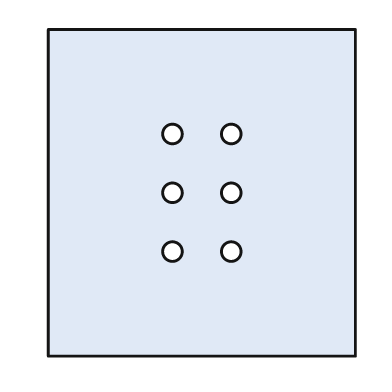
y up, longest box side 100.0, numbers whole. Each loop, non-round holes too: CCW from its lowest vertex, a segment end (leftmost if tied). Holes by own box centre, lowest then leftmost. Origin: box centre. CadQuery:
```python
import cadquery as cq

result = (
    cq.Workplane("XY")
    .moveTo(-47.0, -50.0)
    .lineTo(47.0, -50.0)
    .lineTo(47.0, 50.0)
    .lineTo(-47.0, 50.0)
    .close()
    .moveTo(-9.0, -18.0)
    .circle(3.0)
    .moveTo(9.0, -18.0)
    .circle(3.0)
    .moveTo(-9.0, 0.0)
    .circle(3.0)
    .moveTo(9.0, 0.0)
    .circle(3.0)
    .moveTo(-9.0, 18.0)
    .circle(3.0)
    .moveTo(9.0, 18.0)
    .circle(3.0)
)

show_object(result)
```